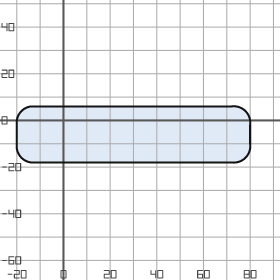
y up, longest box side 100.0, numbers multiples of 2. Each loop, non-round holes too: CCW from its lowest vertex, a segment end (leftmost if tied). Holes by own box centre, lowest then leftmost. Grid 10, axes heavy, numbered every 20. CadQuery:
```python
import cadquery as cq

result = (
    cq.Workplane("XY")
    .moveTo(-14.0, -18.0)
    .lineTo(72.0, -18.0)
    .threePointArc((78.0, -16.0), (80.0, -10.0))
    .lineTo(80.0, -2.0)
    .threePointArc((78.0, 4.0), (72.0, 6.0))
    .lineTo(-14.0, 6.0)
    .threePointArc((-18.0, 4.0), (-20.0, 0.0))
    .lineTo(-20.0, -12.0)
    .threePointArc((-18.0, -16.0), (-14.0, -18.0))
    .close()
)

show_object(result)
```